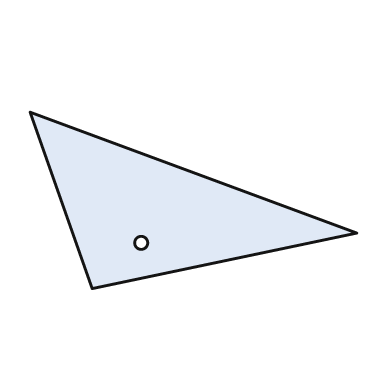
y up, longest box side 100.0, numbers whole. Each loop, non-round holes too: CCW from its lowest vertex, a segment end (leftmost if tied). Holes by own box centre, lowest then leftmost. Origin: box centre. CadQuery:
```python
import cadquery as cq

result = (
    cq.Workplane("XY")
    .moveTo(-31.0, -27.0)
    .lineTo(50.0, -10.0)
    .lineTo(-50.0, 27.0)
    .close()
    .moveTo(-16.0, -13.0)
    .circle(2.0)
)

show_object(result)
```